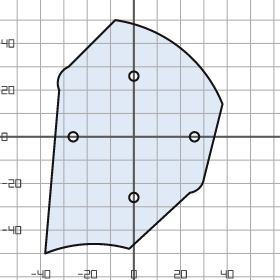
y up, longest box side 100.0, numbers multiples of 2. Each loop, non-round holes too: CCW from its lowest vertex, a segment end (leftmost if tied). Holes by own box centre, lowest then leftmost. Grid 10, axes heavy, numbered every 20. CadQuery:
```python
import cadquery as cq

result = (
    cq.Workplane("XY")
    .moveTo(-38.0, -50.0)
    .threePointArc((-20.0, -46.0), (-2.0, -48.0))
    .lineTo(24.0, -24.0)
    .threePointArc((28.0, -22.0), (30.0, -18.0))
    .lineTo(38.0, 14.0)
    .threePointArc((20.0, 38.0), (-8.0, 50.0))
    .lineTo(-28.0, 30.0)
    .threePointArc((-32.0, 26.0), (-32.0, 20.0))
    .close()
    .moveTo(0.0, -26.0)
    .circle(2.0)
    .moveTo(-26.0, 0.0)
    .circle(2.0)
    .moveTo(26.0, 0.0)
    .circle(2.0)
    .moveTo(0.0, 26.0)
    .circle(2.0)
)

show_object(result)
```